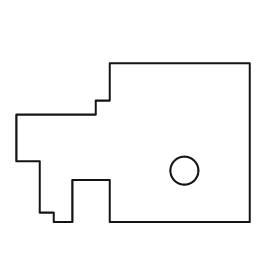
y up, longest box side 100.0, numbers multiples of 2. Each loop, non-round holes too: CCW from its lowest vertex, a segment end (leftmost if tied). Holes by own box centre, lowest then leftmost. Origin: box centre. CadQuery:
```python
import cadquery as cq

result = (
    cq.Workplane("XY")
    .moveTo(-34.0, -34.0)
    .lineTo(-26.0, -34.0)
    .lineTo(-26.0, -16.0)
    .lineTo(-10.0, -16.0)
    .lineTo(-10.0, -34.0)
    .lineTo(50.0, -34.0)
    .lineTo(50.0, 34.0)
    .lineTo(-10.0, 34.0)
    .lineTo(-10.0, 18.0)
    .lineTo(-16.0, 18.0)
    .lineTo(-16.0, 12.0)
    .lineTo(-50.0, 12.0)
    .lineTo(-50.0, -8.0)
    .lineTo(-40.0, -8.0)
    .lineTo(-40.0, -30.0)
    .lineTo(-34.0, -30.0)
    .close()
    .moveTo(22.0, -12.0)
    .circle(6.0)
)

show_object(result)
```